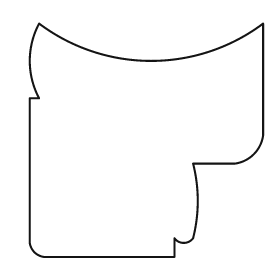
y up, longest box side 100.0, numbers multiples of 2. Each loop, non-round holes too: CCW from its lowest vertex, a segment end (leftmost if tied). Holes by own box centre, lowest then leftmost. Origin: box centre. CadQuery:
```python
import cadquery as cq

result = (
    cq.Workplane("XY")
    .moveTo(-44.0, -50.0)
    .lineTo(12.0, -50.0)
    .lineTo(12.0, -42.0)
    .threePointArc((16.0, -44.0), (20.0, -42.0))
    .threePointArc((22.0, -26.0), (20.0, -10.0))
    .lineTo(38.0, -10.0)
    .threePointArc((46.0, -6.0), (50.0, 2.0))
    .lineTo(50.0, 50.0)
    .threePointArc((2.0, 34.0), (-46.0, 50.0))
    .threePointArc((-50.0, 34.0), (-46.0, 18.0))
    .lineTo(-50.0, 18.0)
    .lineTo(-50.0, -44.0)
    .threePointArc((-48.0, -48.0), (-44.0, -50.0))
    .close()
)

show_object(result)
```